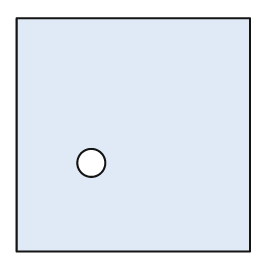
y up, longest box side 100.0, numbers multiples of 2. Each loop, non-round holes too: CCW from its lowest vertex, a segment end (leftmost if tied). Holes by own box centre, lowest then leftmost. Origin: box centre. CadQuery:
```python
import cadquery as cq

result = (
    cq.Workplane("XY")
    .moveTo(-50.0, -50.0)
    .lineTo(50.0, -50.0)
    .lineTo(50.0, 50.0)
    .lineTo(-50.0, 50.0)
    .close()
    .moveTo(-18.0, -12.0)
    .circle(6.0)
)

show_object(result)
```